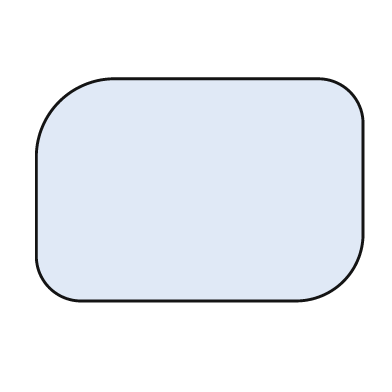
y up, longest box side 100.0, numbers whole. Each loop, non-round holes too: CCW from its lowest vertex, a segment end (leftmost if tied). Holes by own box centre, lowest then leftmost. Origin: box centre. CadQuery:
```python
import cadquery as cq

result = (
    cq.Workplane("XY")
    .moveTo(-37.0, -34.0)
    .lineTo(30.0, -34.0)
    .threePointArc((44.0, -28.0), (50.0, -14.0))
    .lineTo(50.0, 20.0)
    .threePointArc((46.0, 30.0), (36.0, 34.0))
    .lineTo(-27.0, 34.0)
    .threePointArc((-43.0, 27.0), (-50.0, 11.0))
    .lineTo(-50.0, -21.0)
    .threePointArc((-46.0, -30.0), (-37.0, -34.0))
    .close()
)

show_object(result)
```